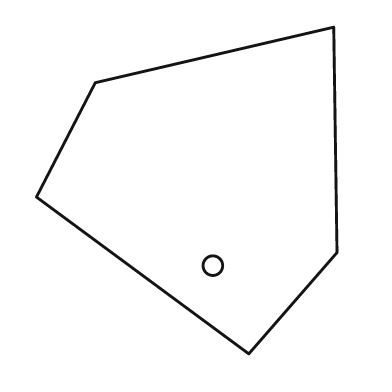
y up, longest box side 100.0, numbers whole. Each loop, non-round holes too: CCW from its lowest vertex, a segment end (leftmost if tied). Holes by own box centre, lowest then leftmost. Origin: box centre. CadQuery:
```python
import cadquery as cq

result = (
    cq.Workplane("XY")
    .moveTo(19.0, -50.0)
    .lineTo(46.0, -19.0)
    .lineTo(45.0, 50.0)
    .lineTo(-28.0, 33.0)
    .lineTo(-46.0, -2.0)
    .close()
    .moveTo(8.0, -23.0)
    .circle(3.0)
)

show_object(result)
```